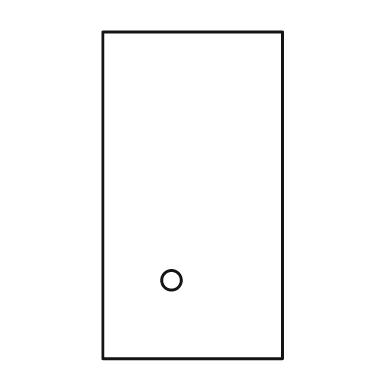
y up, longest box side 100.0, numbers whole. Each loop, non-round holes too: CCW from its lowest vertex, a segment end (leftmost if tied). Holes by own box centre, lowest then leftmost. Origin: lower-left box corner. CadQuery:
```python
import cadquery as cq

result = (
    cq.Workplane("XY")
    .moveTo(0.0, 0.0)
    .lineTo(55.0, 0.0)
    .lineTo(55.0, 100.0)
    .lineTo(0.0, 100.0)
    .close()
    .moveTo(21.0, 24.0)
    .circle(3.0)
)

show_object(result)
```